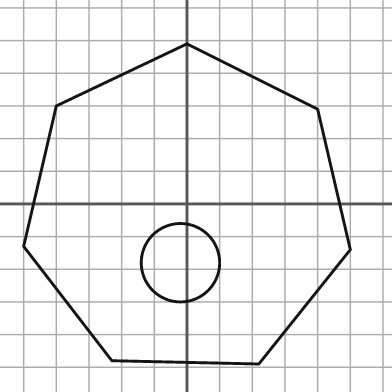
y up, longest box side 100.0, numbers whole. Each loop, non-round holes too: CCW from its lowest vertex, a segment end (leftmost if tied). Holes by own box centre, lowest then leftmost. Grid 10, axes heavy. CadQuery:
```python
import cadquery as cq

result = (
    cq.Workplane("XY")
    .moveTo(22.0, -49.0)
    .lineTo(50.0, -14.0)
    .lineTo(40.0, 29.0)
    .lineTo(0.0, 49.0)
    .lineTo(-40.0, 30.0)
    .lineTo(-50.0, -13.0)
    .lineTo(-23.0, -48.0)
    .close()
    .moveTo(-2.0, -18.0)
    .circle(12.0)
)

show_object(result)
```